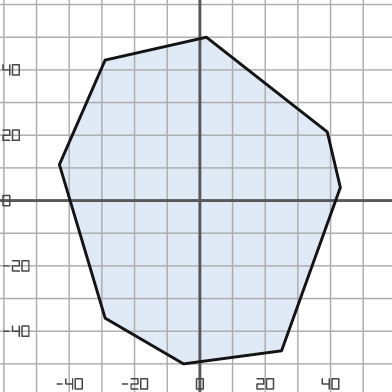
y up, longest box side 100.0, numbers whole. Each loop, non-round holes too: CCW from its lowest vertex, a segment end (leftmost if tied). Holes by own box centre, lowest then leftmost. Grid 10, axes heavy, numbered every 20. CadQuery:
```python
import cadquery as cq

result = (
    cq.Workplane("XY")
    .moveTo(-5.0, -50.0)
    .lineTo(25.0, -46.0)
    .lineTo(43.0, 4.0)
    .lineTo(39.0, 21.0)
    .lineTo(2.0, 50.0)
    .lineTo(-29.0, 43.0)
    .lineTo(-43.0, 11.0)
    .lineTo(-29.0, -36.0)
    .close()
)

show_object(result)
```